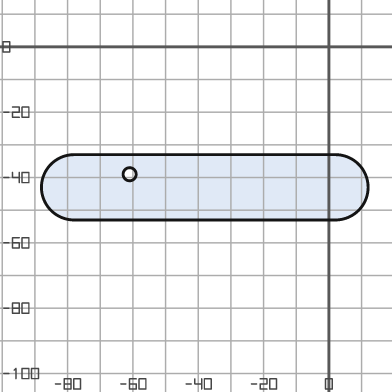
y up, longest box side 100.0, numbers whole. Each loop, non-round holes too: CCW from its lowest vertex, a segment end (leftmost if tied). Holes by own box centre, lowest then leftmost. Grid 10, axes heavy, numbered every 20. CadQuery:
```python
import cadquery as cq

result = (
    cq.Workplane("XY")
    .moveTo(-78.0, -53.0)
    .lineTo(2.0, -53.0)
    .threePointArc((12.0, -43.0), (2.0, -33.0))
    .lineTo(-78.0, -33.0)
    .threePointArc((-88.0, -43.0), (-78.0, -53.0))
    .close()
    .moveTo(-61.0, -39.0)
    .circle(2.0)
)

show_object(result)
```